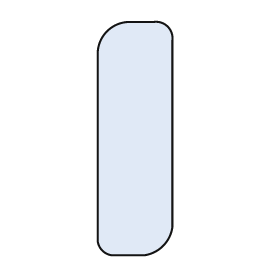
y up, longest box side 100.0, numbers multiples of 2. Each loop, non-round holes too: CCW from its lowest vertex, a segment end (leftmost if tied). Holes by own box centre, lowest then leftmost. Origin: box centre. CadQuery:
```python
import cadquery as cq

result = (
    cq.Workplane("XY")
    .moveTo(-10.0, -50.0)
    .lineTo(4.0, -50.0)
    .threePointArc((12.0, -46.0), (16.0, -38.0))
    .lineTo(16.0, 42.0)
    .threePointArc((14.0, 48.0), (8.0, 50.0))
    .lineTo(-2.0, 50.0)
    .threePointArc((-12.0, 46.0), (-16.0, 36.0))
    .lineTo(-16.0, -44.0)
    .threePointArc((-14.0, -48.0), (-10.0, -50.0))
    .close()
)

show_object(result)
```